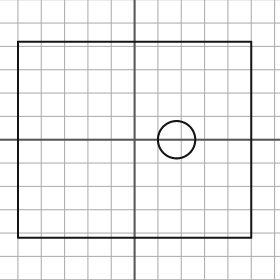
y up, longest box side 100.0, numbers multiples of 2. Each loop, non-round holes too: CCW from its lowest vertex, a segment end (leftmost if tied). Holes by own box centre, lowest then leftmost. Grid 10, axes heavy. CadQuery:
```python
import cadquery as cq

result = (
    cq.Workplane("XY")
    .moveTo(-50.0, -42.0)
    .lineTo(50.0, -42.0)
    .lineTo(50.0, 42.0)
    .lineTo(-50.0, 42.0)
    .close()
    .moveTo(18.0, 0.0)
    .circle(8.0)
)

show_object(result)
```